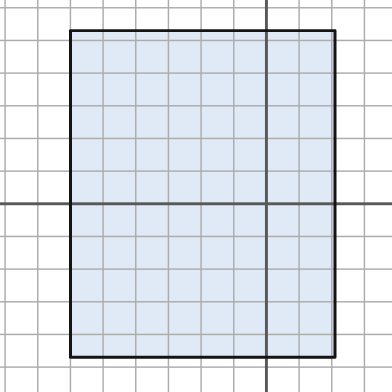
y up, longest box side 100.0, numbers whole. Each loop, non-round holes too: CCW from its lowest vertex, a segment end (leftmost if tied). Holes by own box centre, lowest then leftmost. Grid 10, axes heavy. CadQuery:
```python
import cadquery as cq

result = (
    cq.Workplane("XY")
    .moveTo(-60.0, -47.0)
    .lineTo(21.0, -47.0)
    .lineTo(21.0, 53.0)
    .lineTo(-60.0, 53.0)
    .close()
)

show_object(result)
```